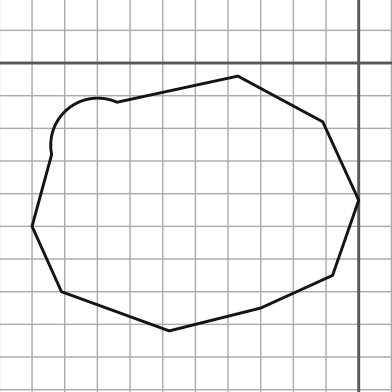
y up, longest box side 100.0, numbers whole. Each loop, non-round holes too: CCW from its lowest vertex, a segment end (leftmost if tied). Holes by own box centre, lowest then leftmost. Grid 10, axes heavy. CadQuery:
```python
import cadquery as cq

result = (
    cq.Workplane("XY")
    .moveTo(-58.0, -82.0)
    .lineTo(-30.0, -75.0)
    .lineTo(-8.0, -65.0)
    .lineTo(0.0, -42.0)
    .lineTo(-11.0, -18.0)
    .lineTo(-37.0, -4.0)
    .lineTo(-74.0, -12.0)
    .threePointArc((-89.0, -14.0), (-94.0, -28.0))
    .lineTo(-100.0, -50.0)
    .lineTo(-91.0, -70.0)
    .close()
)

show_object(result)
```